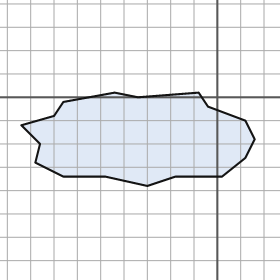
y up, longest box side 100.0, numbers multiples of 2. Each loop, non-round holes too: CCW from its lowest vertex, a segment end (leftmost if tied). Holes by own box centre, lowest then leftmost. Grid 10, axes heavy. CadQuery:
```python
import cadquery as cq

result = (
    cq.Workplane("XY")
    .moveTo(-30.0, -38.0)
    .lineTo(-18.0, -34.0)
    .lineTo(2.0, -34.0)
    .lineTo(12.0, -26.0)
    .lineTo(16.0, -18.0)
    .lineTo(12.0, -10.0)
    .lineTo(-4.0, -4.0)
    .lineTo(-8.0, 2.0)
    .lineTo(-34.0, 0.0)
    .lineTo(-44.0, 2.0)
    .lineTo(-66.0, -2.0)
    .lineTo(-70.0, -8.0)
    .lineTo(-84.0, -12.0)
    .lineTo(-76.0, -20.0)
    .lineTo(-78.0, -28.0)
    .lineTo(-66.0, -34.0)
    .lineTo(-48.0, -34.0)
    .close()
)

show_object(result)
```